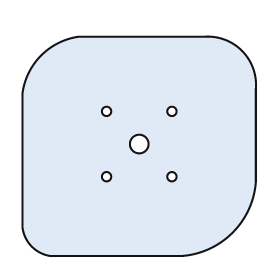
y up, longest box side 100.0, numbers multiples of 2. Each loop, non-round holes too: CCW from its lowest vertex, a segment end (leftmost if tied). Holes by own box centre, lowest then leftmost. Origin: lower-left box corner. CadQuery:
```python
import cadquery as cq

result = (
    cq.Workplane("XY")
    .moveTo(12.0, 0.0)
    .lineTo(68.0, 0.0)
    .threePointArc((90.0, 10.0), (100.0, 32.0))
    .lineTo(100.0, 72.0)
    .threePointArc((94.0, 88.0), (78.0, 94.0))
    .lineTo(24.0, 94.0)
    .threePointArc((8.0, 86.0), (0.0, 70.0))
    .lineTo(0.0, 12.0)
    .threePointArc((4.0, 4.0), (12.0, 0.0))
    .close()
    .moveTo(36.0, 34.0)
    .circle(2.0)
    .moveTo(64.0, 34.0)
    .circle(2.0)
    .moveTo(50.0, 48.0)
    .circle(4.0)
    .moveTo(36.0, 62.0)
    .circle(2.0)
    .moveTo(64.0, 62.0)
    .circle(2.0)
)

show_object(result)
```